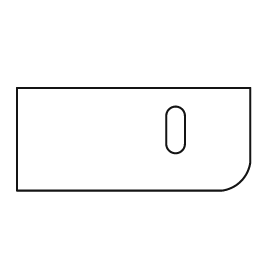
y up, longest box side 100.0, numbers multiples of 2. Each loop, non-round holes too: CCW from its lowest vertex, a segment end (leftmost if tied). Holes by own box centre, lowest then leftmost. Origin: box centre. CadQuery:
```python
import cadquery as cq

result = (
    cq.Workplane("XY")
    .moveTo(-50.0, -22.0)
    .lineTo(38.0, -22.0)
    .threePointArc((46.0, -18.0), (50.0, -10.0))
    .lineTo(50.0, 22.0)
    .lineTo(-50.0, 22.0)
    .close()
    .moveTo(14.0, -2.0)
    .threePointArc((18.0, -6.0), (22.0, -2.0))
    .lineTo(22.0, 10.0)
    .threePointArc((18.0, 14.0), (14.0, 10.0))
    .close()
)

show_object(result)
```